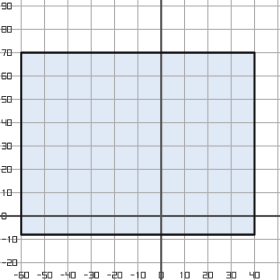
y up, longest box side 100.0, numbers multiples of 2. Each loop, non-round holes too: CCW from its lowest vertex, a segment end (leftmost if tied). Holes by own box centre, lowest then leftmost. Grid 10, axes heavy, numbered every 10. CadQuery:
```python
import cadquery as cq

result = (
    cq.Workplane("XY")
    .moveTo(-60.0, -8.0)
    .lineTo(40.0, -8.0)
    .lineTo(40.0, 70.0)
    .lineTo(-60.0, 70.0)
    .close()
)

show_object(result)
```